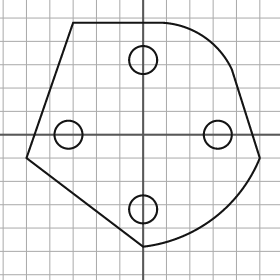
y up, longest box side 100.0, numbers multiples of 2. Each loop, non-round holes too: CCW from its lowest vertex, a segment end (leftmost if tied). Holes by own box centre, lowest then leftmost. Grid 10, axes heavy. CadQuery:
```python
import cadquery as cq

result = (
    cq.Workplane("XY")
    .moveTo(0.0, -48.0)
    .threePointArc((30.0, -36.0), (50.0, -10.0))
    .lineTo(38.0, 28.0)
    .threePointArc((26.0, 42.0), (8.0, 48.0))
    .lineTo(-30.0, 48.0)
    .lineTo(-50.0, -10.0)
    .close()
    .moveTo(0.0, -32.0)
    .circle(6.0)
    .moveTo(-32.0, 0.0)
    .circle(6.0)
    .moveTo(32.0, 0.0)
    .circle(6.0)
    .moveTo(0.0, 32.0)
    .circle(6.0)
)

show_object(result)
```